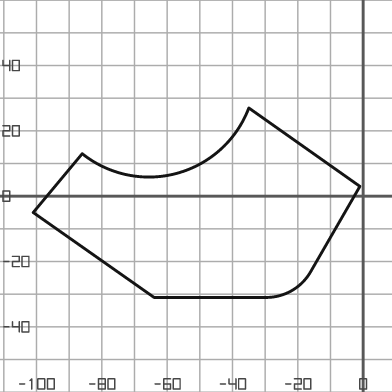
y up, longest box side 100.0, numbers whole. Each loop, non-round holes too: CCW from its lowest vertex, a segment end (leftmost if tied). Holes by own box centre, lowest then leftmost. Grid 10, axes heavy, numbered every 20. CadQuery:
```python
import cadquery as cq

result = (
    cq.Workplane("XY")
    .moveTo(-64.0, -31.0)
    .lineTo(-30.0, -31.0)
    .threePointArc((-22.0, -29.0), (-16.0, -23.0))
    .lineTo(-1.0, 3.0)
    .lineTo(-35.0, 27.0)
    .threePointArc((-57.0, 7.0), (-86.0, 13.0))
    .lineTo(-101.0, -5.0)
    .close()
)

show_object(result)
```